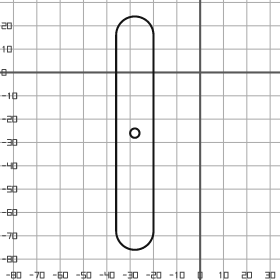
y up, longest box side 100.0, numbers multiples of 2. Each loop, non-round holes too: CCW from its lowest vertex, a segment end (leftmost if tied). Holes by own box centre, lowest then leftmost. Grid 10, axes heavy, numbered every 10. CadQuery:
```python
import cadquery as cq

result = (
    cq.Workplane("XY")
    .moveTo(-36.0, -68.0)
    .threePointArc((-28.0, -76.0), (-20.0, -68.0))
    .lineTo(-20.0, 16.0)
    .threePointArc((-28.0, 24.0), (-36.0, 16.0))
    .close()
    .moveTo(-28.0, -26.0)
    .circle(2.0)
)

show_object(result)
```